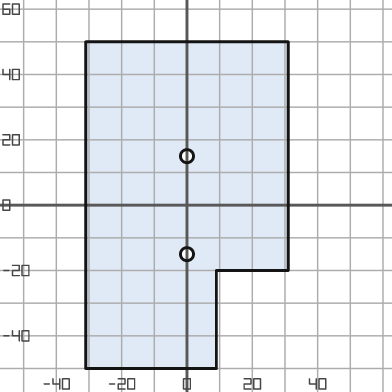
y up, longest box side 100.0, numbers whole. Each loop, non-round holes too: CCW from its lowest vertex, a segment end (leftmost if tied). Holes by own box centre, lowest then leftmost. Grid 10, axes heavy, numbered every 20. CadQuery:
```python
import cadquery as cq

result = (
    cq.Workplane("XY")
    .moveTo(-31.0, -50.0)
    .lineTo(9.0, -50.0)
    .lineTo(9.0, -20.0)
    .lineTo(31.0, -20.0)
    .lineTo(31.0, 50.0)
    .lineTo(-31.0, 50.0)
    .close()
    .moveTo(0.0, -15.0)
    .circle(2.0)
    .moveTo(0.0, 15.0)
    .circle(2.0)
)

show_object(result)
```